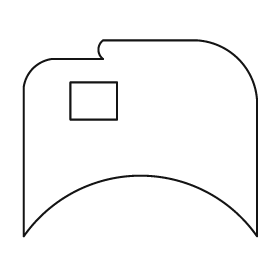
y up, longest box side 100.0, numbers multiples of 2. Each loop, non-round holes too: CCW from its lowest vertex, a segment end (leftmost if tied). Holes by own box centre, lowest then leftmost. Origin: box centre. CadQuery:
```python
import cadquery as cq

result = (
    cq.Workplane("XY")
    .moveTo(-50.0, -42.0)
    .threePointArc((0.0, -16.0), (50.0, -42.0))
    .lineTo(50.0, 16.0)
    .threePointArc((42.0, 34.0), (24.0, 42.0))
    .lineTo(-16.0, 42.0)
    .threePointArc((-18.0, 38.0), (-16.0, 34.0))
    .lineTo(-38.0, 34.0)
    .threePointArc((-46.0, 30.0), (-50.0, 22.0))
    .close()
    .moveTo(-30.0, 8.0)
    .lineTo(-10.0, 8.0)
    .lineTo(-10.0, 24.0)
    .lineTo(-30.0, 24.0)
    .close()
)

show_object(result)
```